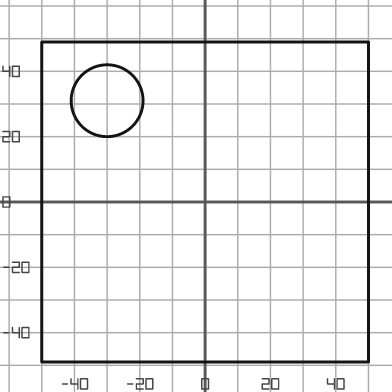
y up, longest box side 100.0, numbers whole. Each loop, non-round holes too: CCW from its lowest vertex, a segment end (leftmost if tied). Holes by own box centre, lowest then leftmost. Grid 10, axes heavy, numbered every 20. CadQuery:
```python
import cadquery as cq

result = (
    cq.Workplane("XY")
    .moveTo(-50.0, -49.0)
    .lineTo(50.0, -49.0)
    .lineTo(50.0, 49.0)
    .lineTo(-50.0, 49.0)
    .close()
    .moveTo(-30.0, 31.0)
    .circle(11.0)
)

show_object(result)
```